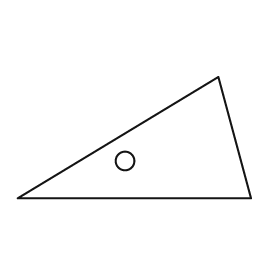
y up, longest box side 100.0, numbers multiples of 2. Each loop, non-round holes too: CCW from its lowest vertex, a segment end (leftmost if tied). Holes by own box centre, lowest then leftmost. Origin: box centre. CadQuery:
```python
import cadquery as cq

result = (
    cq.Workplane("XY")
    .moveTo(-50.0, -26.0)
    .lineTo(50.0, -26.0)
    .lineTo(36.0, 26.0)
    .close()
    .moveTo(-4.0, -10.0)
    .circle(4.0)
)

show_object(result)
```